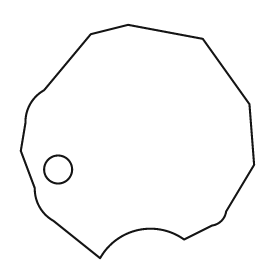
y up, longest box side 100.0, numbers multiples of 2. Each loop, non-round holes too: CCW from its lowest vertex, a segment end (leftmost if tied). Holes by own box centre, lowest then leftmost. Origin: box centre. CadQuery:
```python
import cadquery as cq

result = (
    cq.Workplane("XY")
    .moveTo(-16.0, -50.0)
    .threePointArc((0.0, -38.0), (20.0, -42.0))
    .lineTo(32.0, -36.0)
    .threePointArc((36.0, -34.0), (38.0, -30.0))
    .lineTo(50.0, -10.0)
    .lineTo(48.0, 16.0)
    .lineTo(28.0, 44.0)
    .lineTo(-4.0, 50.0)
    .lineTo(-20.0, 46.0)
    .lineTo(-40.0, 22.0)
    .threePointArc((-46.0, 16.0), (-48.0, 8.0))
    .lineTo(-50.0, -4.0)
    .lineTo(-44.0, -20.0)
    .threePointArc((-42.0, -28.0), (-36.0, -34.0))
    .close()
    .moveTo(-34.0, -12.0)
    .circle(6.0)
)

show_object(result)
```